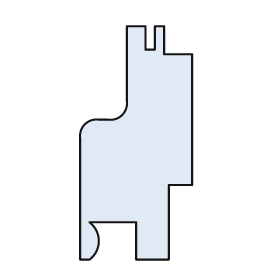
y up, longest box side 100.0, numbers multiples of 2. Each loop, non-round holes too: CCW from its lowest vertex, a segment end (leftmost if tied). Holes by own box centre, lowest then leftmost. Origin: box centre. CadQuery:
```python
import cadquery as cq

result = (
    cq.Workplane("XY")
    .moveTo(-24.0, -50.0)
    .lineTo(-20.0, -50.0)
    .threePointArc((-16.0, -42.0), (-20.0, -34.0))
    .lineTo(0.0, -34.0)
    .lineTo(0.0, -50.0)
    .lineTo(14.0, -50.0)
    .lineTo(14.0, -18.0)
    .lineTo(24.0, -18.0)
    .lineTo(24.0, 38.0)
    .lineTo(12.0, 38.0)
    .lineTo(12.0, 50.0)
    .lineTo(8.0, 50.0)
    .lineTo(8.0, 40.0)
    .lineTo(4.0, 40.0)
    .lineTo(4.0, 50.0)
    .lineTo(-4.0, 50.0)
    .lineTo(-4.0, 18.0)
    .threePointArc((-6.0, 12.0), (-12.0, 10.0))
    .lineTo(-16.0, 10.0)
    .threePointArc((-22.0, 8.0), (-24.0, 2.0))
    .close()
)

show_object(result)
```